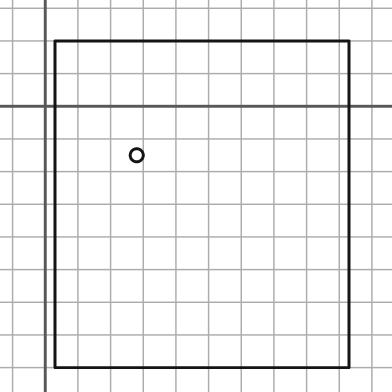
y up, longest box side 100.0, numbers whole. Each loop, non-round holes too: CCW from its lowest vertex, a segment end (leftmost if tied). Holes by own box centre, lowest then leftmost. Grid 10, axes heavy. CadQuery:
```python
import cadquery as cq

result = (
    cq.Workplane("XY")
    .moveTo(3.0, -80.0)
    .lineTo(93.0, -80.0)
    .lineTo(93.0, 20.0)
    .lineTo(3.0, 20.0)
    .close()
    .moveTo(28.0, -15.0)
    .circle(2.0)
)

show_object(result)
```